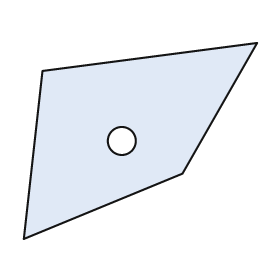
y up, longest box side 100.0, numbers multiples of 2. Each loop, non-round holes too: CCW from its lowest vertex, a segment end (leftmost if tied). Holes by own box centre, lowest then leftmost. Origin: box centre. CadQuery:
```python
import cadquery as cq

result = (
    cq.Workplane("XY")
    .moveTo(-50.0, -42.0)
    .lineTo(18.0, -14.0)
    .lineTo(50.0, 42.0)
    .lineTo(-42.0, 30.0)
    .close()
    .moveTo(-8.0, 0.0)
    .circle(6.0)
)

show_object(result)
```